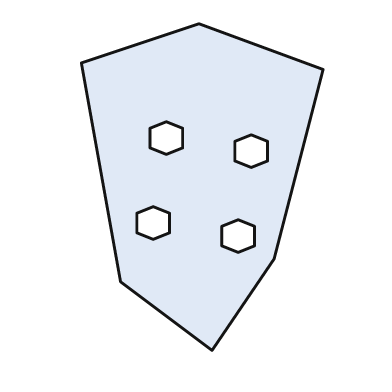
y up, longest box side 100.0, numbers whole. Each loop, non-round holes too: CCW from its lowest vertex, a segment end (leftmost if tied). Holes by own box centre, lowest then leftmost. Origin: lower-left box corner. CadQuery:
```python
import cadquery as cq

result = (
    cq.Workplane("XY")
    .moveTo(40.0, 0.0)
    .lineTo(59.0, 28.0)
    .lineTo(74.0, 86.0)
    .lineTo(36.0, 100.0)
    .lineTo(0.0, 88.0)
    .lineTo(12.0, 21.0)
    .close()
    .moveTo(48.0, 30.0)
    .lineTo(53.0, 32.0)
    .lineTo(53.0, 38.0)
    .lineTo(48.0, 40.0)
    .lineTo(43.0, 38.0)
    .lineTo(43.0, 32.0)
    .close()
    .moveTo(22.0, 34.0)
    .lineTo(27.0, 36.0)
    .lineTo(27.0, 42.0)
    .lineTo(22.0, 44.0)
    .lineTo(17.0, 42.0)
    .lineTo(17.0, 36.0)
    .close()
    .moveTo(52.0, 56.0)
    .lineTo(57.0, 58.0)
    .lineTo(57.0, 64.0)
    .lineTo(52.0, 66.0)
    .lineTo(47.0, 64.0)
    .lineTo(47.0, 58.0)
    .close()
    .moveTo(26.0, 60.0)
    .lineTo(31.0, 62.0)
    .lineTo(31.0, 68.0)
    .lineTo(26.0, 70.0)
    .lineTo(21.0, 68.0)
    .lineTo(21.0, 62.0)
    .close()
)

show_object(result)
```